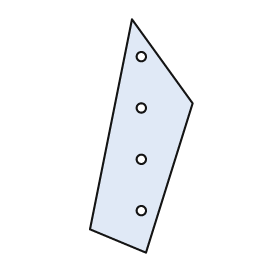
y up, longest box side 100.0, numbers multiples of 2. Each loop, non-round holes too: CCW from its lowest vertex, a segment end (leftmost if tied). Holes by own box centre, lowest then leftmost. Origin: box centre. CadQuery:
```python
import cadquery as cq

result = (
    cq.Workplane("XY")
    .moveTo(2.0, -50.0)
    .lineTo(22.0, 14.0)
    .lineTo(-4.0, 50.0)
    .lineTo(-22.0, -40.0)
    .close()
    .moveTo(0.0, -32.0)
    .circle(2.0)
    .moveTo(0.0, -10.0)
    .circle(2.0)
    .moveTo(0.0, 12.0)
    .circle(2.0)
    .moveTo(0.0, 34.0)
    .circle(2.0)
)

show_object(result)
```